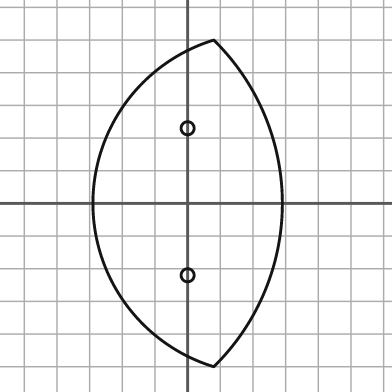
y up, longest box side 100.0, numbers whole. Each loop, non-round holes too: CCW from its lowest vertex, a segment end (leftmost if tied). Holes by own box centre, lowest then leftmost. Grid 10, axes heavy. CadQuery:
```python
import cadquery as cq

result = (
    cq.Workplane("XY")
    .moveTo(8.0, -50.0)
    .threePointArc((29.0, 0.0), (8.0, 50.0))
    .threePointArc((-29.0, 0.0), (8.0, -50.0))
    .close()
    .moveTo(0.0, -22.0)
    .circle(2.0)
    .moveTo(0.0, 23.0)
    .circle(2.0)
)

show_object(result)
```